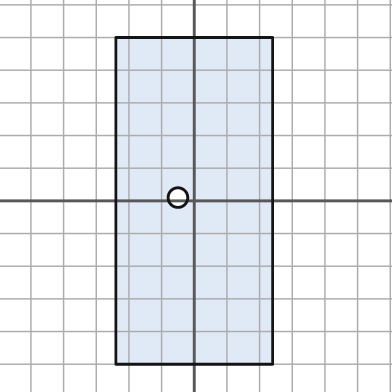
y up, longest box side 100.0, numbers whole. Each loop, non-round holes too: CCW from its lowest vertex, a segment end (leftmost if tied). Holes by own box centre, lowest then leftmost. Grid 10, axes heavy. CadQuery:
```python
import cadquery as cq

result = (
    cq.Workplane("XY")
    .moveTo(-24.0, -50.0)
    .lineTo(24.0, -50.0)
    .lineTo(24.0, 50.0)
    .lineTo(-24.0, 50.0)
    .close()
    .moveTo(-5.0, 1.0)
    .circle(3.0)
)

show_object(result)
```